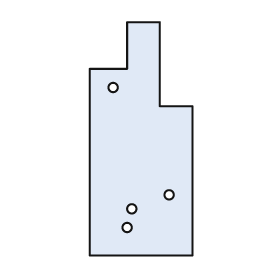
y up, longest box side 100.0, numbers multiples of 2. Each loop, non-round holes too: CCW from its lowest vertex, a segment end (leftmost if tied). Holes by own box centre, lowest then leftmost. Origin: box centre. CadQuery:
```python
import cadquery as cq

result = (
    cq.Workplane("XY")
    .moveTo(-22.0, -50.0)
    .lineTo(22.0, -50.0)
    .lineTo(22.0, 14.0)
    .lineTo(8.0, 14.0)
    .lineTo(8.0, 50.0)
    .lineTo(-6.0, 50.0)
    .lineTo(-6.0, 30.0)
    .lineTo(-22.0, 30.0)
    .close()
    .moveTo(-6.0, -38.0)
    .circle(2.0)
    .moveTo(-4.0, -30.0)
    .circle(2.0)
    .moveTo(12.0, -24.0)
    .circle(2.0)
    .moveTo(-12.0, 22.0)
    .circle(2.0)
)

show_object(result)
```